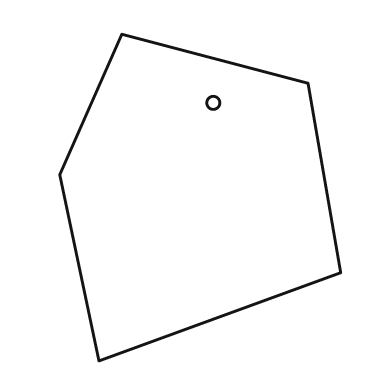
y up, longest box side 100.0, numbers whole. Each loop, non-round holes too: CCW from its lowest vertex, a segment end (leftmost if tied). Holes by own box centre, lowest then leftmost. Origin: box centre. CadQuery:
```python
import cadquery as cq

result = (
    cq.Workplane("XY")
    .moveTo(-31.0, -50.0)
    .lineTo(43.0, -23.0)
    .lineTo(33.0, 35.0)
    .lineTo(-24.0, 50.0)
    .lineTo(-43.0, 7.0)
    .close()
    .moveTo(4.0, 29.0)
    .circle(2.0)
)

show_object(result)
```